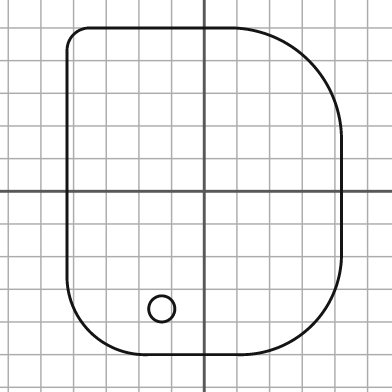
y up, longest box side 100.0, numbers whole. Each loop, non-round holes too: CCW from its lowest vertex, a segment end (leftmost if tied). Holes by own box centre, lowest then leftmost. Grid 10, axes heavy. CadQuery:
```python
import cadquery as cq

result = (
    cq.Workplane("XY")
    .moveTo(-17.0, -50.0)
    .lineTo(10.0, -50.0)
    .threePointArc((33.0, -41.0), (42.0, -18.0))
    .lineTo(42.0, 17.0)
    .threePointArc((32.0, 40.0), (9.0, 50.0))
    .lineTo(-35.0, 50.0)
    .threePointArc((-40.0, 48.0), (-42.0, 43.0))
    .lineTo(-42.0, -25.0)
    .threePointArc((-35.0, -43.0), (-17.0, -50.0))
    .close()
    .moveTo(-13.0, -36.0)
    .circle(4.0)
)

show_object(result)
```